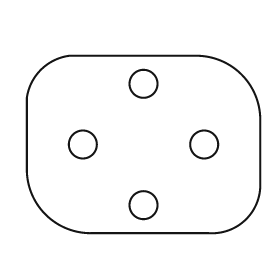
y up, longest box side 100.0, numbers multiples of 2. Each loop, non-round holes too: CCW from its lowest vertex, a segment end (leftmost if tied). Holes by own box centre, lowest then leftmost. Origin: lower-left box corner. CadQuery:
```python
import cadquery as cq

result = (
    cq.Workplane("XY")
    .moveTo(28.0, 0.0)
    .lineTo(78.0, 0.0)
    .threePointArc((94.0, 6.0), (100.0, 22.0))
    .lineTo(100.0, 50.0)
    .threePointArc((92.0, 68.0), (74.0, 76.0))
    .lineTo(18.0, 76.0)
    .threePointArc((6.0, 70.0), (0.0, 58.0))
    .lineTo(0.0, 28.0)
    .threePointArc((8.0, 8.0), (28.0, 0.0))
    .close()
    .moveTo(50.0, 12.0)
    .circle(6.0)
    .moveTo(24.0, 38.0)
    .circle(6.0)
    .moveTo(76.0, 38.0)
    .circle(6.0)
    .moveTo(50.0, 64.0)
    .circle(6.0)
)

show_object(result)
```